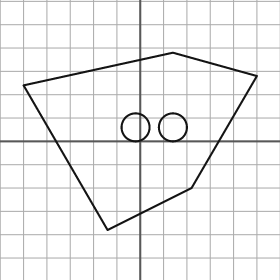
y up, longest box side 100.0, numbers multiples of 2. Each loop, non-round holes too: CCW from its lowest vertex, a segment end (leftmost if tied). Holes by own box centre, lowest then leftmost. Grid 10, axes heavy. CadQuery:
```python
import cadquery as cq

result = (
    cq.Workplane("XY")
    .moveTo(-14.0, -38.0)
    .lineTo(22.0, -20.0)
    .lineTo(50.0, 28.0)
    .lineTo(14.0, 38.0)
    .lineTo(-50.0, 24.0)
    .close()
    .moveTo(-2.0, 6.0)
    .circle(6.0)
    .moveTo(14.0, 6.0)
    .circle(6.0)
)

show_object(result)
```